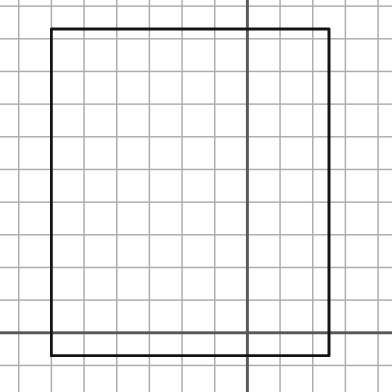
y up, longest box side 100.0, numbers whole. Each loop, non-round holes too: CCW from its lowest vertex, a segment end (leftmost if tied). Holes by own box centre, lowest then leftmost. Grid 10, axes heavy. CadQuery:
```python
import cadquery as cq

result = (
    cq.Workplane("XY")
    .moveTo(-60.0, -7.0)
    .lineTo(25.0, -7.0)
    .lineTo(25.0, 93.0)
    .lineTo(-60.0, 93.0)
    .close()
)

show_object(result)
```